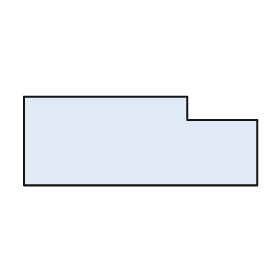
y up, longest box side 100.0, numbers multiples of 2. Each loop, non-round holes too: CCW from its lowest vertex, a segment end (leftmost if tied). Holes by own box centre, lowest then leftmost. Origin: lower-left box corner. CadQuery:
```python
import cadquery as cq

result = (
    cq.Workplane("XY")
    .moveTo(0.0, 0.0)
    .lineTo(100.0, 0.0)
    .lineTo(100.0, 28.0)
    .lineTo(70.0, 28.0)
    .lineTo(70.0, 38.0)
    .lineTo(0.0, 38.0)
    .close()
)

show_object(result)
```